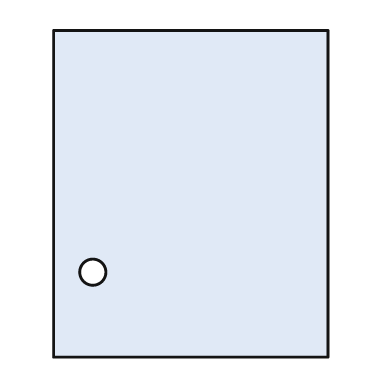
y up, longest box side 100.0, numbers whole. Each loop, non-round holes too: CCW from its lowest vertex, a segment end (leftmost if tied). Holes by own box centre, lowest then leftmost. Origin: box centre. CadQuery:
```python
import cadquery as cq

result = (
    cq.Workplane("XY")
    .moveTo(-42.0, -50.0)
    .lineTo(42.0, -50.0)
    .lineTo(42.0, 50.0)
    .lineTo(-42.0, 50.0)
    .close()
    .moveTo(-30.0, -24.0)
    .circle(4.0)
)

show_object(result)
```